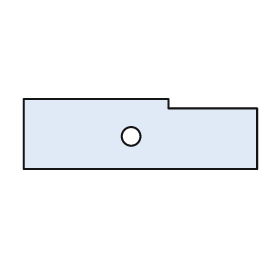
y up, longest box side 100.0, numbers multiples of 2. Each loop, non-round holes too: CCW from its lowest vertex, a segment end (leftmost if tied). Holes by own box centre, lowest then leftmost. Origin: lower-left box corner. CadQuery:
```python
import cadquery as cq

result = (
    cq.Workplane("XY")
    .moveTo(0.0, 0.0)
    .lineTo(100.0, 0.0)
    .lineTo(100.0, 26.0)
    .lineTo(62.0, 26.0)
    .lineTo(62.0, 30.0)
    .lineTo(0.0, 30.0)
    .close()
    .moveTo(46.0, 14.0)
    .circle(4.0)
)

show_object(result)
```